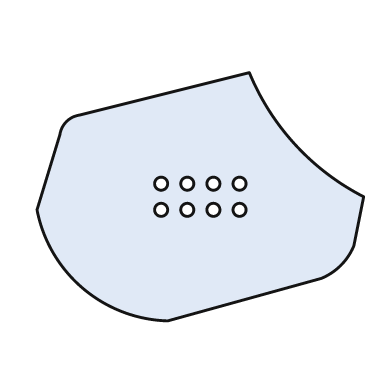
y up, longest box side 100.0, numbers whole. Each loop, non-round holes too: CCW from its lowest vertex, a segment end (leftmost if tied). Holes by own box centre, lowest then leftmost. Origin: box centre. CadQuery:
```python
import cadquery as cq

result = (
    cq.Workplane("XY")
    .moveTo(-10.0, -38.0)
    .lineTo(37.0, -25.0)
    .threePointArc((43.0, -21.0), (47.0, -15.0))
    .lineTo(50.0, 0.0)
    .threePointArc((29.0, 16.0), (15.0, 38.0))
    .lineTo(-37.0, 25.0)
    .threePointArc((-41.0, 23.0), (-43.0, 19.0))
    .lineTo(-50.0, -4.0)
    .threePointArc((-36.0, -28.0), (-10.0, -38.0))
    .close()
    .moveTo(-12.0, -4.0)
    .circle(2.0)
    .moveTo(-4.0, -4.0)
    .circle(2.0)
    .moveTo(4.0, -4.0)
    .circle(2.0)
    .moveTo(12.0, -4.0)
    .circle(2.0)
    .moveTo(-12.0, 4.0)
    .circle(2.0)
    .moveTo(-4.0, 4.0)
    .circle(2.0)
    .moveTo(4.0, 4.0)
    .circle(2.0)
    .moveTo(12.0, 4.0)
    .circle(2.0)
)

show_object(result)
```